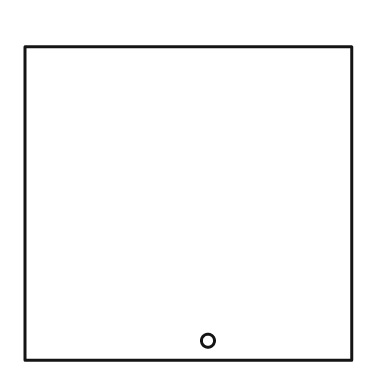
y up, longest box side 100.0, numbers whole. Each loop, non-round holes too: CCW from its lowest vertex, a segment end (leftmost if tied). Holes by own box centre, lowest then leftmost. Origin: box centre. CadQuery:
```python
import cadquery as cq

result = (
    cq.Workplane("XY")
    .moveTo(-50.0, -48.0)
    .lineTo(50.0, -48.0)
    .lineTo(50.0, 48.0)
    .lineTo(-50.0, 48.0)
    .close()
    .moveTo(6.0, -42.0)
    .circle(2.0)
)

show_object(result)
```